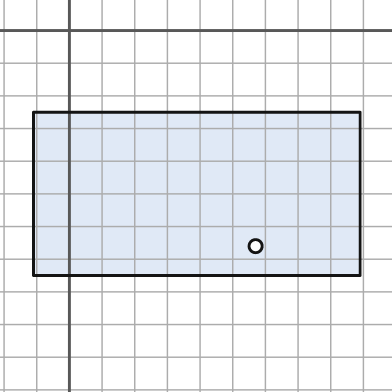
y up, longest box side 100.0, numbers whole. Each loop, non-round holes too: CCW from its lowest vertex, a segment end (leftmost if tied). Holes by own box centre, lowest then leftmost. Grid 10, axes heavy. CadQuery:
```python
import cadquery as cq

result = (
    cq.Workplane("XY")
    .moveTo(-11.0, -75.0)
    .lineTo(89.0, -75.0)
    .lineTo(89.0, -25.0)
    .lineTo(-11.0, -25.0)
    .close()
    .moveTo(57.0, -66.0)
    .circle(2.0)
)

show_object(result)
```